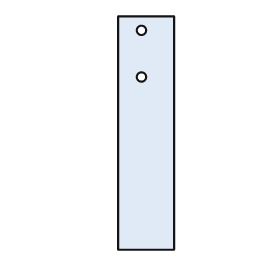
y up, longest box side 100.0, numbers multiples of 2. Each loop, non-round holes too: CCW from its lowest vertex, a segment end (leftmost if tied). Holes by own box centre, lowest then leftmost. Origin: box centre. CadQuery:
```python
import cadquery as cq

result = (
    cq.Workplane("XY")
    .moveTo(-12.0, -50.0)
    .lineTo(12.0, -50.0)
    .lineTo(12.0, 50.0)
    .lineTo(-12.0, 50.0)
    .close()
    .moveTo(-2.0, 24.0)
    .circle(2.0)
    .moveTo(-2.0, 44.0)
    .circle(2.0)
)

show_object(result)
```